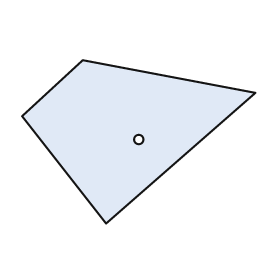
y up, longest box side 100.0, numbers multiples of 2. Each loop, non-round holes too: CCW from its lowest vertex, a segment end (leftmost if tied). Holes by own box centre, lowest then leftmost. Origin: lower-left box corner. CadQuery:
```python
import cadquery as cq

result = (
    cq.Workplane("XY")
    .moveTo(36.0, 0.0)
    .lineTo(100.0, 56.0)
    .lineTo(26.0, 70.0)
    .lineTo(0.0, 46.0)
    .close()
    .moveTo(50.0, 36.0)
    .circle(2.0)
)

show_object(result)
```